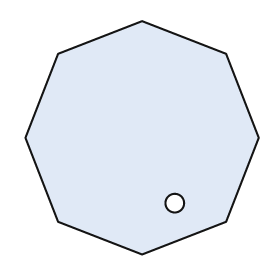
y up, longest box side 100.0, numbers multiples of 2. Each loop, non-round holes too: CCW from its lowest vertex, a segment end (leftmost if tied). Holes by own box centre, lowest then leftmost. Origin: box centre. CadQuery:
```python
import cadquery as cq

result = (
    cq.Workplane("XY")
    .moveTo(0.0, -50.0)
    .lineTo(36.0, -36.0)
    .lineTo(50.0, 0.0)
    .lineTo(36.0, 36.0)
    .lineTo(0.0, 50.0)
    .lineTo(-36.0, 36.0)
    .lineTo(-50.0, 0.0)
    .lineTo(-36.0, -36.0)
    .close()
    .moveTo(14.0, -28.0)
    .circle(4.0)
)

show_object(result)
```